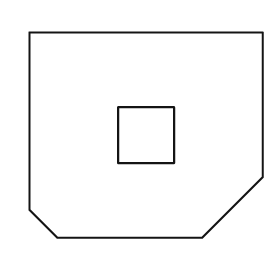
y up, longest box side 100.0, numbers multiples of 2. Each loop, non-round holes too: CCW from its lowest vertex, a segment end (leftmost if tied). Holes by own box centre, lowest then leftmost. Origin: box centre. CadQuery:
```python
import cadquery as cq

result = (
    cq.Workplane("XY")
    .moveTo(-38.0, -44.0)
    .lineTo(24.0, -44.0)
    .lineTo(50.0, -18.0)
    .lineTo(50.0, 44.0)
    .lineTo(-50.0, 44.0)
    .lineTo(-50.0, -32.0)
    .close()
    .moveTo(-12.0, -12.0)
    .lineTo(12.0, -12.0)
    .lineTo(12.0, 12.0)
    .lineTo(-12.0, 12.0)
    .close()
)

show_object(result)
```